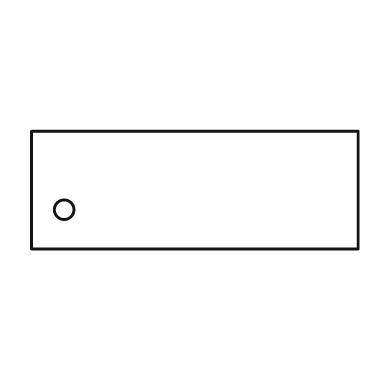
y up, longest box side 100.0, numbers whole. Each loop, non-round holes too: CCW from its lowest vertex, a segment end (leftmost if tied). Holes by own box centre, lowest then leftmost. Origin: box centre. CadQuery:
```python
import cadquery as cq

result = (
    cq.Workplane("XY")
    .moveTo(-50.0, -18.0)
    .lineTo(50.0, -18.0)
    .lineTo(50.0, 18.0)
    .lineTo(-50.0, 18.0)
    .close()
    .moveTo(-40.0, -6.0)
    .circle(3.0)
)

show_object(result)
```